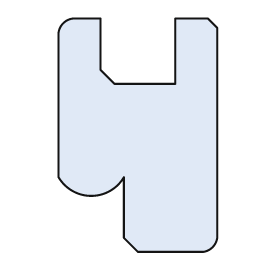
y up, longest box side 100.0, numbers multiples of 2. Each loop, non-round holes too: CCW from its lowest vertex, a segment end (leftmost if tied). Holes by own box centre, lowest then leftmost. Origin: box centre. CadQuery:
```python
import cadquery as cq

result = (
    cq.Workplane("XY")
    .moveTo(0.0, -50.0)
    .lineTo(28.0, -50.0)
    .threePointArc((32.0, -48.0), (34.0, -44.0))
    .lineTo(34.0, 46.0)
    .lineTo(30.0, 50.0)
    .lineTo(16.0, 50.0)
    .lineTo(16.0, 22.0)
    .lineTo(-10.0, 22.0)
    .lineTo(-16.0, 28.0)
    .lineTo(-16.0, 50.0)
    .lineTo(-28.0, 50.0)
    .threePointArc((-32.0, 48.0), (-34.0, 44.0))
    .lineTo(-34.0, -18.0)
    .threePointArc((-20.0, -26.0), (-6.0, -18.0))
    .lineTo(-6.0, -44.0)
    .close()
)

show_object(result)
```